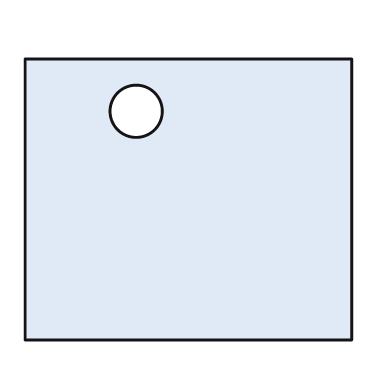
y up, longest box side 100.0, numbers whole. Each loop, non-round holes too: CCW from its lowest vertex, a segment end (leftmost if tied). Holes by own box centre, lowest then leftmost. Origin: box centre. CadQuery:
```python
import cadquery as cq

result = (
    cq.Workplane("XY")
    .moveTo(-50.0, -43.0)
    .lineTo(50.0, -43.0)
    .lineTo(50.0, 43.0)
    .lineTo(-50.0, 43.0)
    .close()
    .moveTo(-16.0, 27.0)
    .circle(8.0)
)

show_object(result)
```